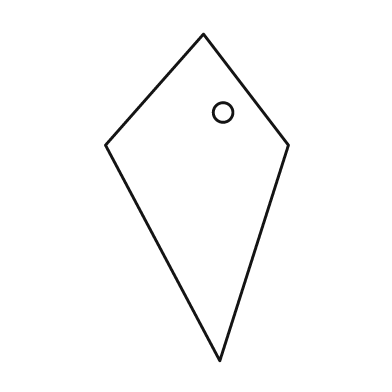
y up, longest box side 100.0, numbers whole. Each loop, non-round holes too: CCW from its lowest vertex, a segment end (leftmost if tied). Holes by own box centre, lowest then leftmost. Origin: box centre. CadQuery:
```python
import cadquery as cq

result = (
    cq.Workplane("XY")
    .moveTo(7.0, -50.0)
    .lineTo(28.0, 16.0)
    .lineTo(2.0, 50.0)
    .lineTo(-28.0, 16.0)
    .close()
    .moveTo(8.0, 26.0)
    .circle(3.0)
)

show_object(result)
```